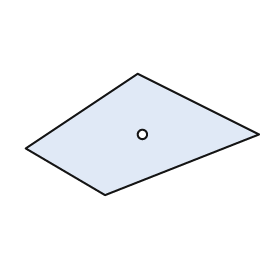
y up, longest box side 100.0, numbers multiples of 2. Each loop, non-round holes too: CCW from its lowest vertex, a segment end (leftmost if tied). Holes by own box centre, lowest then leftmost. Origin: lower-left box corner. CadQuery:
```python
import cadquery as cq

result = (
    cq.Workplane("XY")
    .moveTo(34.0, 0.0)
    .lineTo(100.0, 26.0)
    .lineTo(48.0, 52.0)
    .lineTo(0.0, 20.0)
    .close()
    .moveTo(50.0, 26.0)
    .circle(2.0)
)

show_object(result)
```